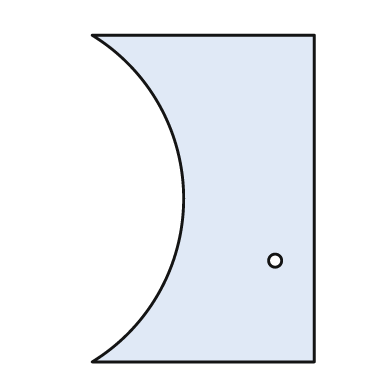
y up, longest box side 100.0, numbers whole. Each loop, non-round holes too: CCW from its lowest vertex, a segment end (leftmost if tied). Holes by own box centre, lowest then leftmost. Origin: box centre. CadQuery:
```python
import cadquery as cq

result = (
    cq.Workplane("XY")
    .moveTo(-34.0, -50.0)
    .lineTo(34.0, -50.0)
    .lineTo(34.0, 50.0)
    .lineTo(-34.0, 50.0)
    .threePointArc((-6.0, 0.0), (-34.0, -50.0))
    .close()
    .moveTo(22.0, -19.0)
    .circle(2.0)
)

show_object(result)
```